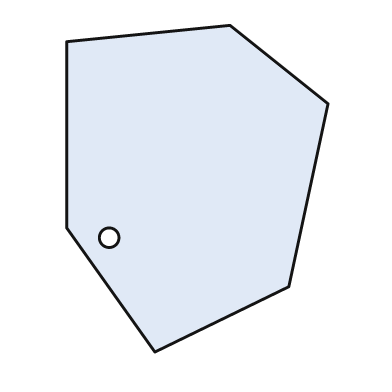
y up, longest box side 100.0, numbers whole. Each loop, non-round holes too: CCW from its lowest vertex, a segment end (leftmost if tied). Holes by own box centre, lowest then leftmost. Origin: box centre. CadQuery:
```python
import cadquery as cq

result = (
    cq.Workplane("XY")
    .moveTo(-13.0, -50.0)
    .lineTo(28.0, -30.0)
    .lineTo(40.0, 26.0)
    .lineTo(10.0, 50.0)
    .lineTo(-40.0, 45.0)
    .lineTo(-40.0, -12.0)
    .close()
    .moveTo(-27.0, -15.0)
    .circle(3.0)
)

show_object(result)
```